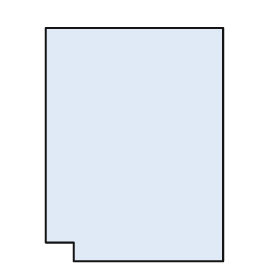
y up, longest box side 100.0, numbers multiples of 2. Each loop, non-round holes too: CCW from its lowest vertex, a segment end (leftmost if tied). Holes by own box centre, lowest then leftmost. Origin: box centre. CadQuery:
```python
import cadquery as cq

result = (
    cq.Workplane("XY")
    .moveTo(-26.0, -50.0)
    .lineTo(38.0, -50.0)
    .lineTo(38.0, 50.0)
    .lineTo(-38.0, 50.0)
    .lineTo(-38.0, -42.0)
    .lineTo(-26.0, -42.0)
    .close()
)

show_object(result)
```